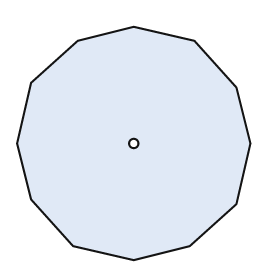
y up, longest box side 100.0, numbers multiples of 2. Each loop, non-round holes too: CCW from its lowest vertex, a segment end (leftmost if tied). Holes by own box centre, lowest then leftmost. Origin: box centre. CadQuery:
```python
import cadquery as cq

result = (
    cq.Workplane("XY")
    .moveTo(0.0, -50.0)
    .lineTo(24.0, -44.0)
    .lineTo(44.0, -26.0)
    .lineTo(50.0, 0.0)
    .lineTo(44.0, 24.0)
    .lineTo(26.0, 44.0)
    .lineTo(0.0, 50.0)
    .lineTo(-24.0, 44.0)
    .lineTo(-44.0, 26.0)
    .lineTo(-50.0, 0.0)
    .lineTo(-44.0, -24.0)
    .lineTo(-26.0, -44.0)
    .close()
    .moveTo(0.0, 0.0)
    .circle(2.0)
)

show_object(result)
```